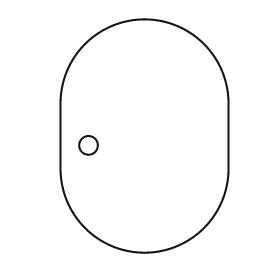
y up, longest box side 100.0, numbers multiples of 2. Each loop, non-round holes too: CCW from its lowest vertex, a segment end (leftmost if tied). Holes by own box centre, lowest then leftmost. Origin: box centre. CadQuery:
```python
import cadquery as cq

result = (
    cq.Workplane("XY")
    .moveTo(-36.0, -14.0)
    .threePointArc((0.0, -50.0), (36.0, -14.0))
    .lineTo(36.0, 14.0)
    .threePointArc((0.0, 50.0), (-36.0, 14.0))
    .close()
    .moveTo(-24.0, -4.0)
    .circle(4.0)
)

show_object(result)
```